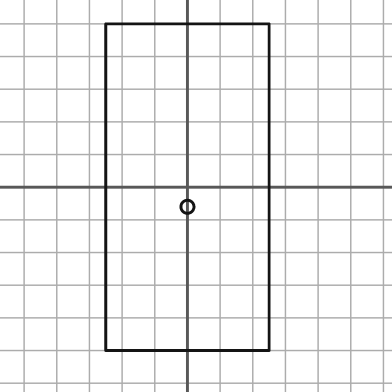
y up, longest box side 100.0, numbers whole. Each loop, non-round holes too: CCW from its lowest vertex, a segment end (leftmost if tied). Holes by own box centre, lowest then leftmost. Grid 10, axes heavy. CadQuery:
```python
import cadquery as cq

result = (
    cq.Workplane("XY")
    .moveTo(-25.0, -50.0)
    .lineTo(25.0, -50.0)
    .lineTo(25.0, 50.0)
    .lineTo(-25.0, 50.0)
    .close()
    .moveTo(0.0, -6.0)
    .circle(2.0)
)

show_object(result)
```